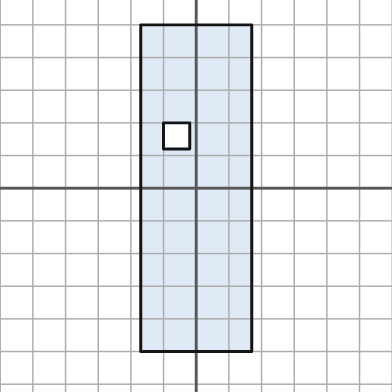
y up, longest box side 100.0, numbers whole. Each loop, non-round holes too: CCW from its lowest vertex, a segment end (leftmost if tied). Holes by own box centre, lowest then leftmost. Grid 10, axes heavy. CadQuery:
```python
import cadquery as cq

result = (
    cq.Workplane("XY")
    .moveTo(-17.0, -50.0)
    .lineTo(17.0, -50.0)
    .lineTo(17.0, 50.0)
    .lineTo(-17.0, 50.0)
    .close()
    .moveTo(-10.0, 12.0)
    .lineTo(-2.0, 12.0)
    .lineTo(-2.0, 20.0)
    .lineTo(-10.0, 20.0)
    .close()
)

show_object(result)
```